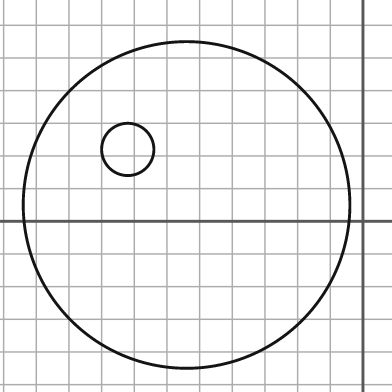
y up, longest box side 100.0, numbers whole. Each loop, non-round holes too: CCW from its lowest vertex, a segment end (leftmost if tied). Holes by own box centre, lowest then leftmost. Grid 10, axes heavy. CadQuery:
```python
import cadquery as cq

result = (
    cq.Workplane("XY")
    .moveTo(-54.0, 5.0)
    .circle(50.0)
    .moveTo(-72.0, 22.0)
    .circle(8.0)
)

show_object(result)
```